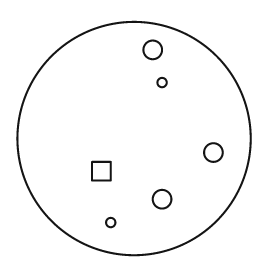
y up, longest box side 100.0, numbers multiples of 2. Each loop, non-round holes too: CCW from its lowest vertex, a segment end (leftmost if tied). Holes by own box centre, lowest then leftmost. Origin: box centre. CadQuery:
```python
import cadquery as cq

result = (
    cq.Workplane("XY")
    .moveTo(0.0, 0.0)
    .circle(50.0)
    .moveTo(-10.0, -36.0)
    .circle(2.0)
    .moveTo(12.0, -26.0)
    .circle(4.0)
    .moveTo(-18.0, -18.0)
    .lineTo(-10.0, -18.0)
    .lineTo(-10.0, -10.0)
    .lineTo(-18.0, -10.0)
    .close()
    .moveTo(34.0, -6.0)
    .circle(4.0)
    .moveTo(12.0, 24.0)
    .circle(2.0)
    .moveTo(8.0, 38.0)
    .circle(4.0)
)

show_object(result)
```